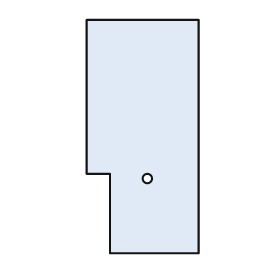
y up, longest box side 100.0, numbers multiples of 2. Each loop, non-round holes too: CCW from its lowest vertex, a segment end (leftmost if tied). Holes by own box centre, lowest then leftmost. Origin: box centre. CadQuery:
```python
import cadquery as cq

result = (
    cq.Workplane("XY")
    .moveTo(-14.0, -50.0)
    .lineTo(24.0, -50.0)
    .lineTo(24.0, 50.0)
    .lineTo(-24.0, 50.0)
    .lineTo(-24.0, -16.0)
    .lineTo(-14.0, -16.0)
    .close()
    .moveTo(2.0, -18.0)
    .circle(2.0)
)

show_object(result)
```